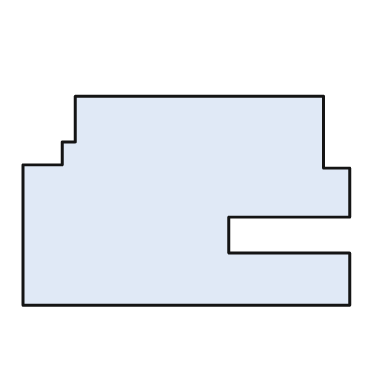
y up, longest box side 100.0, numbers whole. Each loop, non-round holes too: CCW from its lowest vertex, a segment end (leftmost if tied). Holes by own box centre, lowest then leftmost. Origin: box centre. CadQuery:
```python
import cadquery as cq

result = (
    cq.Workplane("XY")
    .moveTo(-50.0, -32.0)
    .lineTo(50.0, -32.0)
    .lineTo(50.0, -16.0)
    .lineTo(13.0, -16.0)
    .lineTo(13.0, -5.0)
    .lineTo(50.0, -5.0)
    .lineTo(50.0, 10.0)
    .lineTo(42.0, 10.0)
    .lineTo(42.0, 32.0)
    .lineTo(-34.0, 32.0)
    .lineTo(-34.0, 18.0)
    .lineTo(-38.0, 18.0)
    .lineTo(-38.0, 11.0)
    .lineTo(-50.0, 11.0)
    .close()
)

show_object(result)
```